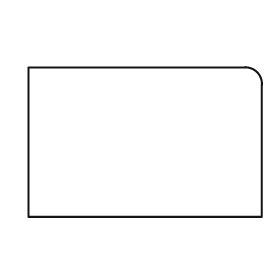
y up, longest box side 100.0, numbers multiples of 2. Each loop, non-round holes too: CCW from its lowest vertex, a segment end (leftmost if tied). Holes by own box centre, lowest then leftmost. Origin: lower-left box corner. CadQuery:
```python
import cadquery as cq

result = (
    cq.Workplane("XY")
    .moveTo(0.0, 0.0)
    .lineTo(100.0, 0.0)
    .lineTo(100.0, 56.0)
    .threePointArc((98.0, 62.0), (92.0, 64.0))
    .lineTo(0.0, 64.0)
    .close()
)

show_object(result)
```